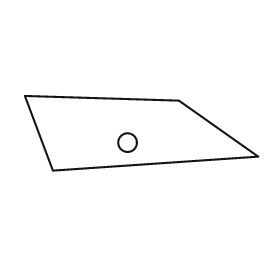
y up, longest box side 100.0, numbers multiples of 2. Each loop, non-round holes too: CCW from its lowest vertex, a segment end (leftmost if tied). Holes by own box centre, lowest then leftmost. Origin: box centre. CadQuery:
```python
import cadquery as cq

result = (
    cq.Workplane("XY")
    .moveTo(-38.0, -16.0)
    .lineTo(50.0, -10.0)
    .lineTo(16.0, 14.0)
    .lineTo(-50.0, 16.0)
    .close()
    .moveTo(-6.0, -4.0)
    .circle(4.0)
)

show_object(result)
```